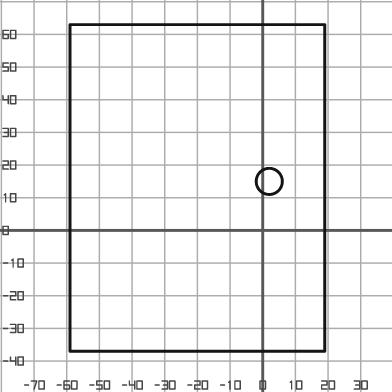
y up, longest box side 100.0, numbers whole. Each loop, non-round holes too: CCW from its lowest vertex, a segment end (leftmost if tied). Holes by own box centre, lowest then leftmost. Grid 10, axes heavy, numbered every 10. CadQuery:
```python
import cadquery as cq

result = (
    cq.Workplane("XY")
    .moveTo(-59.0, -37.0)
    .lineTo(19.0, -37.0)
    .lineTo(19.0, 63.0)
    .lineTo(-59.0, 63.0)
    .close()
    .moveTo(2.0, 15.0)
    .circle(4.0)
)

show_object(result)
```